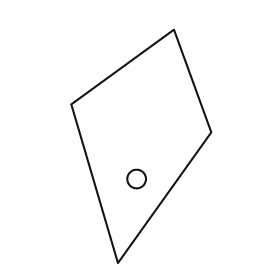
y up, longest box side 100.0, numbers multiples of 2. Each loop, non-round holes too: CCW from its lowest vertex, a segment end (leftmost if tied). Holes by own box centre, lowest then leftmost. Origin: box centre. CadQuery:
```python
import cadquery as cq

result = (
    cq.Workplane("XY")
    .moveTo(-10.0, -50.0)
    .lineTo(30.0, 6.0)
    .lineTo(14.0, 50.0)
    .lineTo(-30.0, 18.0)
    .close()
    .moveTo(-2.0, -14.0)
    .circle(4.0)
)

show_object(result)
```